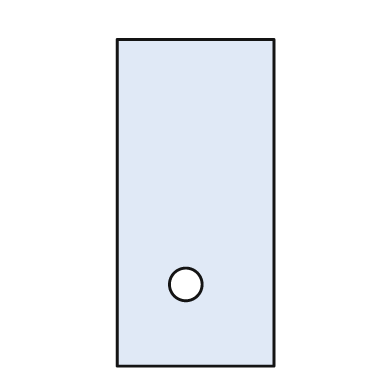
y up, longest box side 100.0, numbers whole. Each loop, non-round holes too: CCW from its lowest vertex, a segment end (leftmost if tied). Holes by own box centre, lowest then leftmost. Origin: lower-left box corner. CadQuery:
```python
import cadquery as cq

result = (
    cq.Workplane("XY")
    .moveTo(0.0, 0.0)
    .lineTo(48.0, 0.0)
    .lineTo(48.0, 100.0)
    .lineTo(0.0, 100.0)
    .close()
    .moveTo(21.0, 25.0)
    .circle(5.0)
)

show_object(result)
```